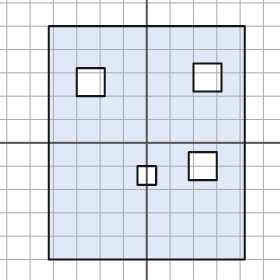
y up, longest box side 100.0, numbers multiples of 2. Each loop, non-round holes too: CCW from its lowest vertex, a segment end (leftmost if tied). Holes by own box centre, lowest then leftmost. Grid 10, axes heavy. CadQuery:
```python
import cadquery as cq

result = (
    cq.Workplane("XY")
    .moveTo(-42.0, -50.0)
    .lineTo(42.0, -50.0)
    .lineTo(42.0, 50.0)
    .lineTo(-42.0, 50.0)
    .close()
    .moveTo(-4.0, -18.0)
    .lineTo(4.0, -18.0)
    .lineTo(4.0, -10.0)
    .lineTo(-4.0, -10.0)
    .close()
    .moveTo(18.0, -16.0)
    .lineTo(30.0, -16.0)
    .lineTo(30.0, -4.0)
    .lineTo(18.0, -4.0)
    .close()
    .moveTo(-30.0, 20.0)
    .lineTo(-18.0, 20.0)
    .lineTo(-18.0, 32.0)
    .lineTo(-30.0, 32.0)
    .close()
    .moveTo(20.0, 22.0)
    .lineTo(32.0, 22.0)
    .lineTo(32.0, 34.0)
    .lineTo(20.0, 34.0)
    .close()
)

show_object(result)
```